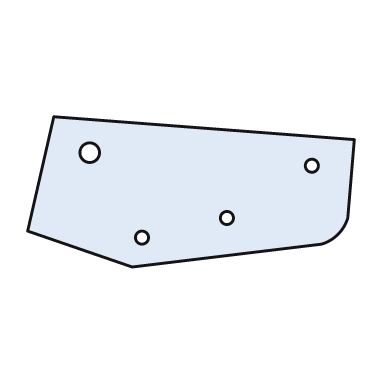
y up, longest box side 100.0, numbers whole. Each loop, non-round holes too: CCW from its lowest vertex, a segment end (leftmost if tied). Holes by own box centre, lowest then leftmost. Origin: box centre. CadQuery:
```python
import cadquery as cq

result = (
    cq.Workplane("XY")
    .moveTo(-18.0, -23.0)
    .lineTo(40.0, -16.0)
    .threePointArc((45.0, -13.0), (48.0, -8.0))
    .lineTo(50.0, 16.0)
    .lineTo(-42.0, 23.0)
    .lineTo(-50.0, -12.0)
    .close()
    .moveTo(-15.0, -14.0)
    .circle(2.0)
    .moveTo(11.0, -8.0)
    .circle(2.0)
    .moveTo(37.0, 8.0)
    .circle(2.0)
    .moveTo(-31.0, 12.0)
    .circle(3.0)
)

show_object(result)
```